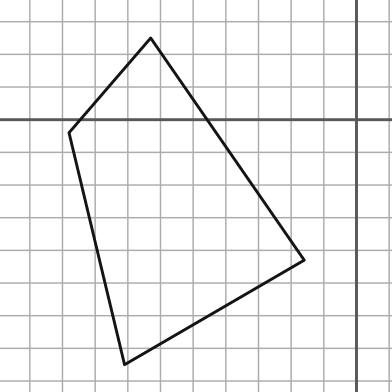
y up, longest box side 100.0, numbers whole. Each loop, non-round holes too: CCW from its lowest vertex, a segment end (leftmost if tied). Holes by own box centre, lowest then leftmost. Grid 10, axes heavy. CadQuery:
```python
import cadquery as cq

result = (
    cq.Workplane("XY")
    .moveTo(-71.0, -75.0)
    .lineTo(-16.0, -43.0)
    .lineTo(-63.0, 25.0)
    .lineTo(-88.0, -4.0)
    .close()
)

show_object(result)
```